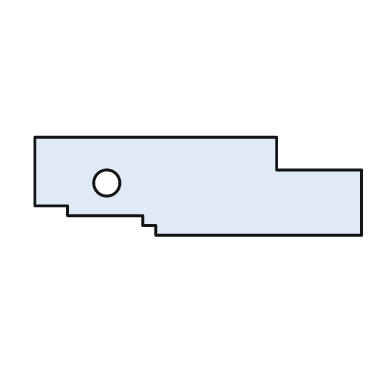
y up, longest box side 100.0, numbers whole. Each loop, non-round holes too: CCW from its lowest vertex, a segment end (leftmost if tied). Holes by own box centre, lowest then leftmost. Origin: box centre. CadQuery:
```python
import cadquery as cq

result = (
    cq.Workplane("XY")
    .moveTo(-13.0, -15.0)
    .lineTo(50.0, -15.0)
    .lineTo(50.0, 5.0)
    .lineTo(24.0, 5.0)
    .lineTo(24.0, 15.0)
    .lineTo(-50.0, 15.0)
    .lineTo(-50.0, -6.0)
    .lineTo(-40.0, -6.0)
    .lineTo(-40.0, -9.0)
    .lineTo(-17.0, -9.0)
    .lineTo(-17.0, -12.0)
    .lineTo(-13.0, -12.0)
    .close()
    .moveTo(-28.0, 1.0)
    .circle(4.0)
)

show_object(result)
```